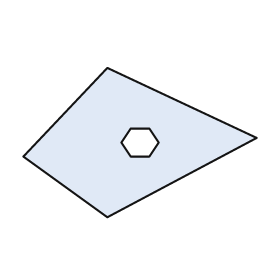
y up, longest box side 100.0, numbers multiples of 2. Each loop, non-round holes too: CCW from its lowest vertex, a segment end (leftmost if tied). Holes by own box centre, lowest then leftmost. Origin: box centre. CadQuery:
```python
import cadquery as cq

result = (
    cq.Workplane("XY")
    .moveTo(-14.0, -32.0)
    .lineTo(50.0, 2.0)
    .lineTo(-14.0, 32.0)
    .lineTo(-50.0, -6.0)
    .close()
    .moveTo(-4.0, -6.0)
    .lineTo(4.0, -6.0)
    .lineTo(8.0, 0.0)
    .lineTo(4.0, 6.0)
    .lineTo(-4.0, 6.0)
    .lineTo(-8.0, 0.0)
    .close()
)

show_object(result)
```